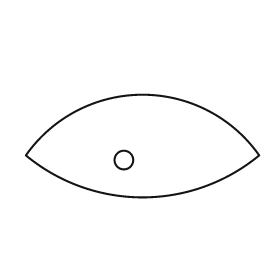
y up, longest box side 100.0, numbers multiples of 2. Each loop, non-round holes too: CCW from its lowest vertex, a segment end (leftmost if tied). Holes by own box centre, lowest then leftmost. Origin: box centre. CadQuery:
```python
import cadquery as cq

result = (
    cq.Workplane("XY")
    .moveTo(-50.0, -4.0)
    .threePointArc((0.0, -22.0), (50.0, -4.0))
    .threePointArc((0.0, 22.0), (-50.0, -4.0))
    .close()
    .moveTo(-8.0, -6.0)
    .circle(4.0)
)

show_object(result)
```